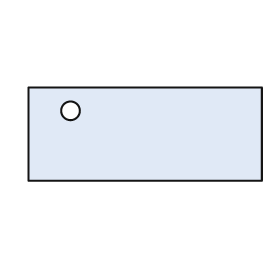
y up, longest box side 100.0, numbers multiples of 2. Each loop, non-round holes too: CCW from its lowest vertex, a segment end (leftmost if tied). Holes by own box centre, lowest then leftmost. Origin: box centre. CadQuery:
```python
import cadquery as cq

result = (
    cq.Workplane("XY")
    .moveTo(-50.0, -20.0)
    .lineTo(50.0, -20.0)
    .lineTo(50.0, 20.0)
    .lineTo(-50.0, 20.0)
    .close()
    .moveTo(-32.0, 10.0)
    .circle(4.0)
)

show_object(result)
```